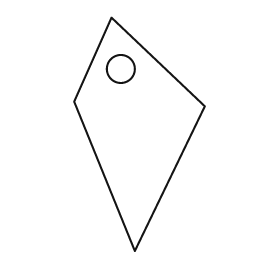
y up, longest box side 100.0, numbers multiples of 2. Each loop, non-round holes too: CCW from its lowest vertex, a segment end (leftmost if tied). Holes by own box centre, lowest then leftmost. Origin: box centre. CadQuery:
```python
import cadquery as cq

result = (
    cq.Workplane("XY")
    .moveTo(-2.0, -50.0)
    .lineTo(28.0, 12.0)
    .lineTo(-12.0, 50.0)
    .lineTo(-28.0, 14.0)
    .close()
    .moveTo(-8.0, 28.0)
    .circle(6.0)
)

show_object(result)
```